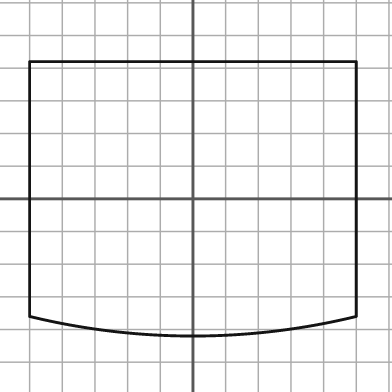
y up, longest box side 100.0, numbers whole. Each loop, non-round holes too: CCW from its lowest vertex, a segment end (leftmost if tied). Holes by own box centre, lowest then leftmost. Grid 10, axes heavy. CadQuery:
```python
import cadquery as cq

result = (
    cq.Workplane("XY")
    .moveTo(-50.0, -36.0)
    .threePointArc((0.0, -42.0), (50.0, -36.0))
    .lineTo(50.0, 42.0)
    .lineTo(-50.0, 42.0)
    .close()
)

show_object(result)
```